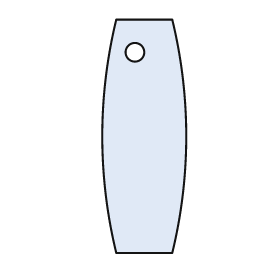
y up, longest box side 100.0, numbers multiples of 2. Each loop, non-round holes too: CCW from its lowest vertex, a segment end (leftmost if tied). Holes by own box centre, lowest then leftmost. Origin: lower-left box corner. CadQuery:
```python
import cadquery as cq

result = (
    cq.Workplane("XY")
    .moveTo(6.0, 0.0)
    .lineTo(30.0, 0.0)
    .threePointArc((36.0, 50.0), (30.0, 100.0))
    .lineTo(6.0, 100.0)
    .threePointArc((0.0, 50.0), (6.0, 0.0))
    .close()
    .moveTo(14.0, 86.0)
    .circle(4.0)
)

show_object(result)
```